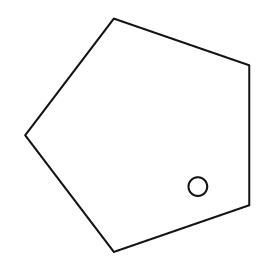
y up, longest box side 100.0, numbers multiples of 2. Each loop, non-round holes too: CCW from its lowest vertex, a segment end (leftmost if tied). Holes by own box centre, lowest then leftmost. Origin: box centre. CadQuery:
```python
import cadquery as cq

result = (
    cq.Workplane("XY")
    .moveTo(-10.0, -50.0)
    .lineTo(48.0, -30.0)
    .lineTo(48.0, 30.0)
    .lineTo(-10.0, 50.0)
    .lineTo(-48.0, 0.0)
    .close()
    .moveTo(26.0, -22.0)
    .circle(4.0)
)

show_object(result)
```